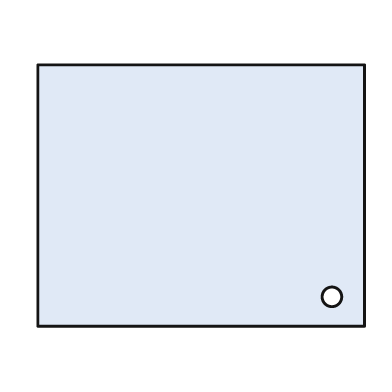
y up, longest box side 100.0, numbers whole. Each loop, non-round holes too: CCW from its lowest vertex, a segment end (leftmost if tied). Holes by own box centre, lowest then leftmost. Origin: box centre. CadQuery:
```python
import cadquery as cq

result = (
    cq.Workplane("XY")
    .moveTo(-50.0, -40.0)
    .lineTo(50.0, -40.0)
    .lineTo(50.0, 40.0)
    .lineTo(-50.0, 40.0)
    .close()
    .moveTo(40.0, -31.0)
    .circle(3.0)
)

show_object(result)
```